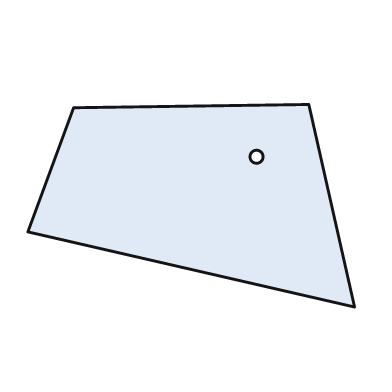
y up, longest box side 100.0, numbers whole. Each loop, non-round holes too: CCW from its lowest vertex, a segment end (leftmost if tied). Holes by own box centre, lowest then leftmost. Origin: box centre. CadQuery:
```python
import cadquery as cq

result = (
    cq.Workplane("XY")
    .moveTo(50.0, -31.0)
    .lineTo(36.0, 31.0)
    .lineTo(-36.0, 30.0)
    .lineTo(-50.0, -8.0)
    .close()
    .moveTo(20.0, 15.0)
    .circle(2.0)
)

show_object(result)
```